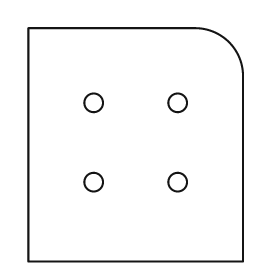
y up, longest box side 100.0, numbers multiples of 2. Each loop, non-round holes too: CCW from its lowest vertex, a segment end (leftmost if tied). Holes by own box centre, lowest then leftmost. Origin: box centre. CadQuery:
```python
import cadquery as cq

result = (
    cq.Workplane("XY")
    .moveTo(-46.0, -50.0)
    .lineTo(46.0, -50.0)
    .lineTo(46.0, 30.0)
    .threePointArc((40.0, 44.0), (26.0, 50.0))
    .lineTo(-46.0, 50.0)
    .close()
    .moveTo(-18.0, -16.0)
    .circle(4.0)
    .moveTo(18.0, -16.0)
    .circle(4.0)
    .moveTo(-18.0, 18.0)
    .circle(4.0)
    .moveTo(18.0, 18.0)
    .circle(4.0)
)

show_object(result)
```